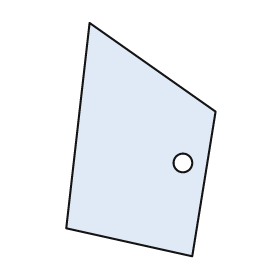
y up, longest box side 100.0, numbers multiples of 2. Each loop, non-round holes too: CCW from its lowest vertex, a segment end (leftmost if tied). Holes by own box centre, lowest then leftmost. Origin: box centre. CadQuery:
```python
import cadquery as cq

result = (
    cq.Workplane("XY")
    .moveTo(22.0, -50.0)
    .lineTo(32.0, 12.0)
    .lineTo(-22.0, 50.0)
    .lineTo(-32.0, -38.0)
    .close()
    .moveTo(18.0, -10.0)
    .circle(4.0)
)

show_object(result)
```